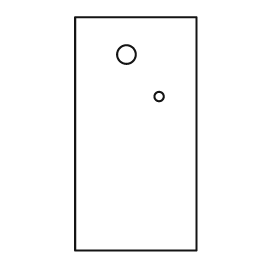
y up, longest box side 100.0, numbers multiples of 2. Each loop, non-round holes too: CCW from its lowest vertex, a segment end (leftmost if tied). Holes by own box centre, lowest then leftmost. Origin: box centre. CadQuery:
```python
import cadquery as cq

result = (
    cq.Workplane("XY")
    .moveTo(-26.0, -50.0)
    .lineTo(26.0, -50.0)
    .lineTo(26.0, 50.0)
    .lineTo(-26.0, 50.0)
    .close()
    .moveTo(10.0, 16.0)
    .circle(2.0)
    .moveTo(-4.0, 34.0)
    .circle(4.0)
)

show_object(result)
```